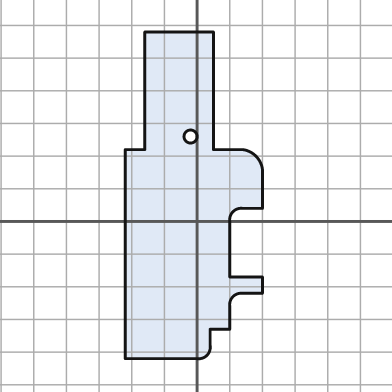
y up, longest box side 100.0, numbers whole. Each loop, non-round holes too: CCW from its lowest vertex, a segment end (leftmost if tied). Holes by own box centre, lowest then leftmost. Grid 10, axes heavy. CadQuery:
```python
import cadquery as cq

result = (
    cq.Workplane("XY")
    .moveTo(-22.0, -42.0)
    .lineTo(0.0, -42.0)
    .threePointArc((3.0, -41.0), (4.0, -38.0))
    .lineTo(4.0, -33.0)
    .lineTo(10.0, -33.0)
    .lineTo(10.0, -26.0)
    .threePointArc((11.0, -23.0), (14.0, -22.0))
    .lineTo(20.0, -22.0)
    .lineTo(20.0, -17.0)
    .lineTo(10.0, -17.0)
    .lineTo(10.0, 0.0)
    .threePointArc((11.0, 3.0), (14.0, 4.0))
    .lineTo(20.0, 4.0)
    .lineTo(20.0, 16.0)
    .threePointArc((18.0, 20.0), (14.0, 22.0))
    .lineTo(5.0, 22.0)
    .lineTo(5.0, 58.0)
    .lineTo(-16.0, 58.0)
    .lineTo(-16.0, 22.0)
    .lineTo(-22.0, 22.0)
    .close()
    .moveTo(-2.0, 26.0)
    .circle(2.0)
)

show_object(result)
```